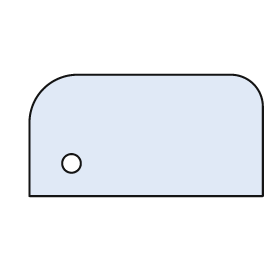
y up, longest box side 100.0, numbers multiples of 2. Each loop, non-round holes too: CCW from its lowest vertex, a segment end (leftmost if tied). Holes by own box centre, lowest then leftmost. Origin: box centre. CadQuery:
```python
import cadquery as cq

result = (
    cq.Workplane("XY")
    .moveTo(-50.0, -26.0)
    .lineTo(50.0, -26.0)
    .lineTo(50.0, 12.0)
    .threePointArc((46.0, 22.0), (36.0, 26.0))
    .lineTo(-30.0, 26.0)
    .threePointArc((-44.0, 20.0), (-50.0, 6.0))
    .close()
    .moveTo(-32.0, -12.0)
    .circle(4.0)
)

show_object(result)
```